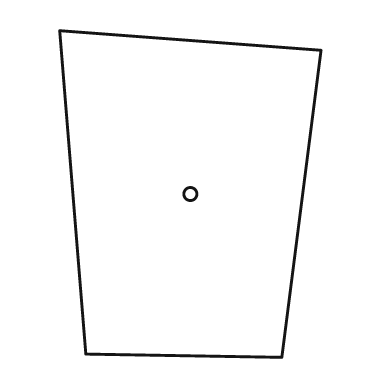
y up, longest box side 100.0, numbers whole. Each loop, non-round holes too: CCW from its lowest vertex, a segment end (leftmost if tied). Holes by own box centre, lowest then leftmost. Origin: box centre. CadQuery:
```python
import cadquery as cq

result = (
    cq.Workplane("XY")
    .moveTo(28.0, -50.0)
    .lineTo(40.0, 44.0)
    .lineTo(-40.0, 50.0)
    .lineTo(-32.0, -49.0)
    .close()
    .moveTo(0.0, 0.0)
    .circle(2.0)
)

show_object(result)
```